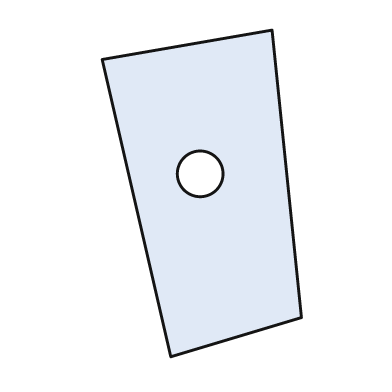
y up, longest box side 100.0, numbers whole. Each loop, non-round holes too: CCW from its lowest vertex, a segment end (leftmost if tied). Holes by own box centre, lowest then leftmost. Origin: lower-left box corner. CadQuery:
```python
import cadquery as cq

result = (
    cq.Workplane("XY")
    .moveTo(21.0, 0.0)
    .lineTo(61.0, 12.0)
    .lineTo(52.0, 100.0)
    .lineTo(0.0, 91.0)
    .close()
    .moveTo(30.0, 56.0)
    .circle(7.0)
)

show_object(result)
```